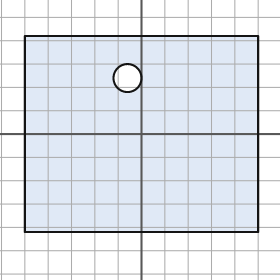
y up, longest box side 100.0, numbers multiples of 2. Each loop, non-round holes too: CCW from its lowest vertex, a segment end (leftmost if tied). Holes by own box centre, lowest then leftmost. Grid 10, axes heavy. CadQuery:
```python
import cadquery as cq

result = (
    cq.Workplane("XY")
    .moveTo(-50.0, -42.0)
    .lineTo(50.0, -42.0)
    .lineTo(50.0, 42.0)
    .lineTo(-50.0, 42.0)
    .close()
    .moveTo(-6.0, 24.0)
    .circle(6.0)
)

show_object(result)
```